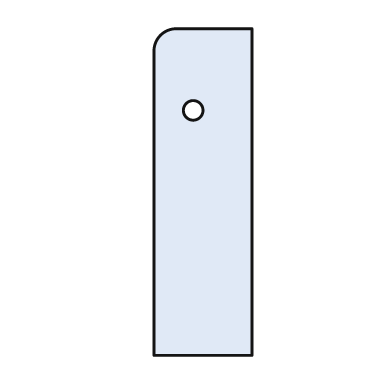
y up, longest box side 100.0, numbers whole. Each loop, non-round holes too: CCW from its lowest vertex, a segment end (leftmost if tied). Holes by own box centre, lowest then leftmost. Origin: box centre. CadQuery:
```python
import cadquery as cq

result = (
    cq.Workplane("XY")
    .moveTo(-15.0, -50.0)
    .lineTo(15.0, -50.0)
    .lineTo(15.0, 50.0)
    .lineTo(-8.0, 50.0)
    .threePointArc((-13.0, 48.0), (-15.0, 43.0))
    .close()
    .moveTo(-3.0, 25.0)
    .circle(3.0)
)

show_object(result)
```